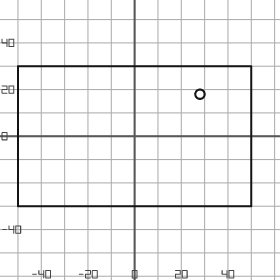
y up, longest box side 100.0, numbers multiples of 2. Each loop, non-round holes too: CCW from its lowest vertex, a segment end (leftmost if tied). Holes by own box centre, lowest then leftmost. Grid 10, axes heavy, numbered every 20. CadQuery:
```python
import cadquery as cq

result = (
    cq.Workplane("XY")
    .moveTo(-50.0, -30.0)
    .lineTo(50.0, -30.0)
    .lineTo(50.0, 30.0)
    .lineTo(-50.0, 30.0)
    .close()
    .moveTo(28.0, 18.0)
    .circle(2.0)
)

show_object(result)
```